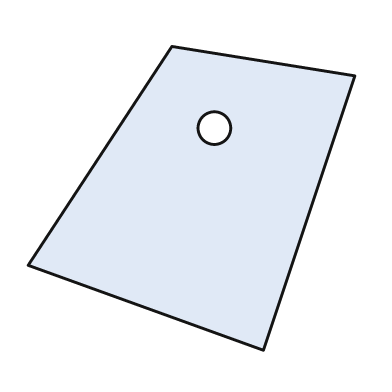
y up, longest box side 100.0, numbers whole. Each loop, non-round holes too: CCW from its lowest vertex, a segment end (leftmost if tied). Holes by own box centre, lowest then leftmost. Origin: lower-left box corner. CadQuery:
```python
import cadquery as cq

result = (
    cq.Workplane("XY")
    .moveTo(72.0, 0.0)
    .lineTo(100.0, 84.0)
    .lineTo(44.0, 93.0)
    .lineTo(0.0, 26.0)
    .close()
    .moveTo(57.0, 68.0)
    .circle(5.0)
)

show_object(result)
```